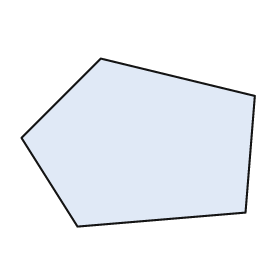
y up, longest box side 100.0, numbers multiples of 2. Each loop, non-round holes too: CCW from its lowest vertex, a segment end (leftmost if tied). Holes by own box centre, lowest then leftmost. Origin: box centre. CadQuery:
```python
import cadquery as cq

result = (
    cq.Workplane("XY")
    .moveTo(-26.0, -36.0)
    .lineTo(46.0, -30.0)
    .lineTo(50.0, 20.0)
    .lineTo(-16.0, 36.0)
    .lineTo(-50.0, 2.0)
    .close()
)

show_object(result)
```